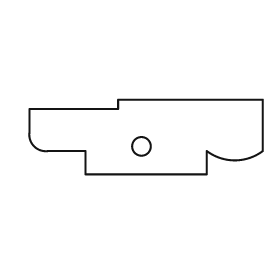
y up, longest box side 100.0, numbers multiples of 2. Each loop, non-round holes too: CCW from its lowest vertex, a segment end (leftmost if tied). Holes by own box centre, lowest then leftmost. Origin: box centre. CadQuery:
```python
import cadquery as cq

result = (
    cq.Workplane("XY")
    .moveTo(-26.0, -16.0)
    .lineTo(26.0, -16.0)
    .lineTo(26.0, -6.0)
    .threePointArc((38.0, -10.0), (50.0, -6.0))
    .lineTo(50.0, 16.0)
    .lineTo(-12.0, 16.0)
    .lineTo(-12.0, 12.0)
    .lineTo(-50.0, 12.0)
    .lineTo(-50.0, 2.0)
    .threePointArc((-48.0, -4.0), (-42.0, -6.0))
    .lineTo(-26.0, -6.0)
    .close()
    .moveTo(-2.0, -4.0)
    .circle(4.0)
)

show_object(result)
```